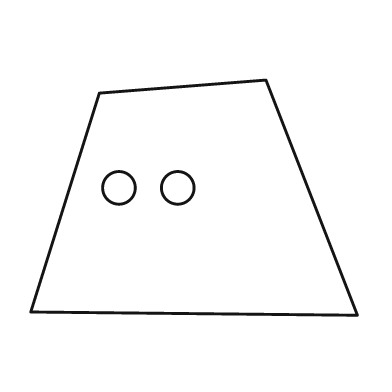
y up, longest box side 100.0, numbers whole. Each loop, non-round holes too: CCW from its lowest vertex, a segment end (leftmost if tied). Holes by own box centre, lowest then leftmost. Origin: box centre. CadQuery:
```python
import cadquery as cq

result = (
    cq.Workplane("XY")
    .moveTo(50.0, -36.0)
    .lineTo(22.0, 36.0)
    .lineTo(-29.0, 32.0)
    .lineTo(-50.0, -35.0)
    .close()
    .moveTo(-23.0, 3.0)
    .circle(5.0)
    .moveTo(-5.0, 3.0)
    .circle(5.0)
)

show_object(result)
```